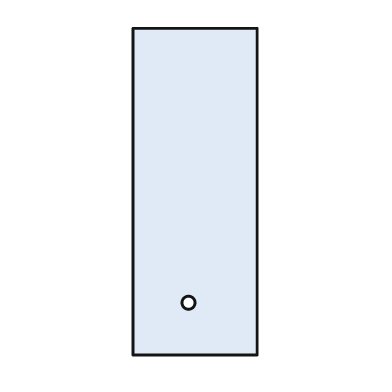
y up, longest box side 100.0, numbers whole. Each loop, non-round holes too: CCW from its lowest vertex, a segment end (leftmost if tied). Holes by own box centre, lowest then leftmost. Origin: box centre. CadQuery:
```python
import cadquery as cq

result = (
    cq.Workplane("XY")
    .moveTo(-19.0, -50.0)
    .lineTo(19.0, -50.0)
    .lineTo(19.0, 50.0)
    .lineTo(-19.0, 50.0)
    .close()
    .moveTo(-2.0, -34.0)
    .circle(2.0)
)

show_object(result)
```